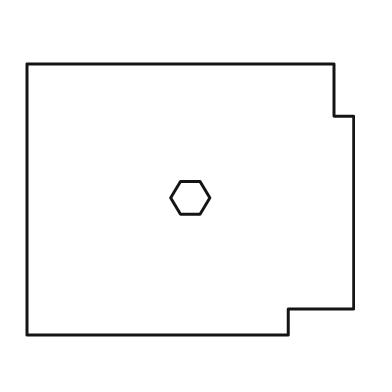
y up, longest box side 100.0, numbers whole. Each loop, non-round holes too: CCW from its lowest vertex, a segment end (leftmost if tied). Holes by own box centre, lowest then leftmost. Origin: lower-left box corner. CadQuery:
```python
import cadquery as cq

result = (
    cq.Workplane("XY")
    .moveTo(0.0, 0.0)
    .lineTo(80.0, 0.0)
    .lineTo(80.0, 8.0)
    .lineTo(100.0, 8.0)
    .lineTo(100.0, 67.0)
    .lineTo(94.0, 67.0)
    .lineTo(94.0, 83.0)
    .lineTo(0.0, 83.0)
    .close()
    .moveTo(47.0, 37.0)
    .lineTo(53.0, 37.0)
    .lineTo(56.0, 42.0)
    .lineTo(53.0, 47.0)
    .lineTo(47.0, 47.0)
    .lineTo(44.0, 42.0)
    .close()
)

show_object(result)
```